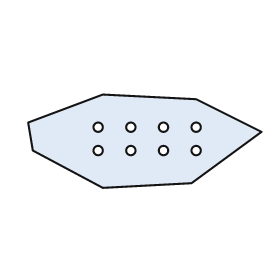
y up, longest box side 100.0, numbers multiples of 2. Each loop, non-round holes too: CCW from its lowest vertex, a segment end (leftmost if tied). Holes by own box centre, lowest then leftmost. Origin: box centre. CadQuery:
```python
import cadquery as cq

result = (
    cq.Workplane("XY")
    .moveTo(-18.0, -20.0)
    .lineTo(20.0, -18.0)
    .lineTo(50.0, 4.0)
    .lineTo(22.0, 18.0)
    .lineTo(-18.0, 20.0)
    .lineTo(-50.0, 8.0)
    .lineTo(-48.0, -4.0)
    .close()
    .moveTo(-20.0, -4.0)
    .circle(2.0)
    .moveTo(-6.0, -4.0)
    .circle(2.0)
    .moveTo(8.0, -4.0)
    .circle(2.0)
    .moveTo(22.0, -4.0)
    .circle(2.0)
    .moveTo(-20.0, 6.0)
    .circle(2.0)
    .moveTo(-6.0, 6.0)
    .circle(2.0)
    .moveTo(8.0, 6.0)
    .circle(2.0)
    .moveTo(22.0, 6.0)
    .circle(2.0)
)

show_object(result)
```